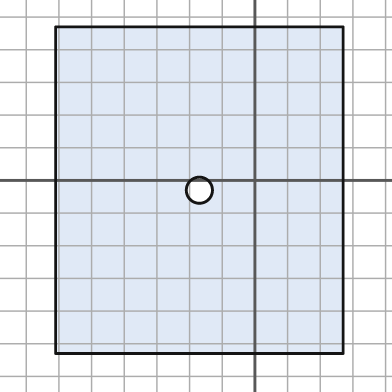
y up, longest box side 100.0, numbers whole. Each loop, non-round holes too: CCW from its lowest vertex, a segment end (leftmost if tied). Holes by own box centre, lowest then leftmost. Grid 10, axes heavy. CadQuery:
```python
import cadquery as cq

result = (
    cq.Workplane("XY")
    .moveTo(-61.0, -53.0)
    .lineTo(27.0, -53.0)
    .lineTo(27.0, 47.0)
    .lineTo(-61.0, 47.0)
    .close()
    .moveTo(-17.0, -3.0)
    .circle(4.0)
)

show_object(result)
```